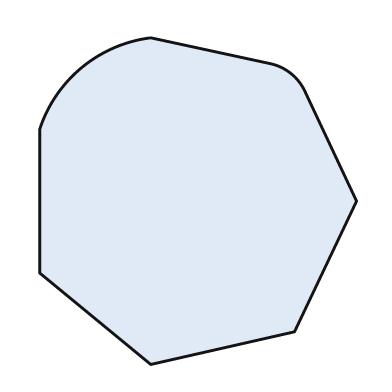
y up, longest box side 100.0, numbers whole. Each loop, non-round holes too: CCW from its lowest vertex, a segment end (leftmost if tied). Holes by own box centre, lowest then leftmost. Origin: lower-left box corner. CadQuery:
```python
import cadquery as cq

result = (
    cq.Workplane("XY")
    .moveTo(34.0, 0.0)
    .lineTo(78.0, 10.0)
    .lineTo(97.0, 50.0)
    .lineTo(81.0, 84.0)
    .threePointArc((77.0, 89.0), (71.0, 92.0))
    .lineTo(34.0, 100.0)
    .threePointArc((13.0, 91.0), (0.0, 72.0))
    .lineTo(0.0, 28.0)
    .close()
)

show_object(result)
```